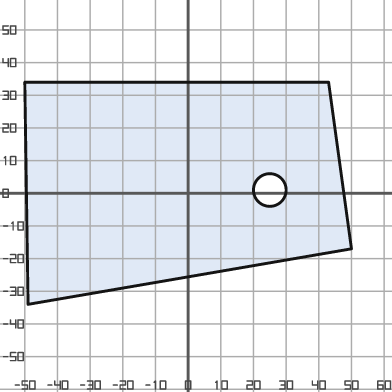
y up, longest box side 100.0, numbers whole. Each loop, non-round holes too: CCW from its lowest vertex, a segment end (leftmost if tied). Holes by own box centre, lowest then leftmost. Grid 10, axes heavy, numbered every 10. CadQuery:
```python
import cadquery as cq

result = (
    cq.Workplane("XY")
    .moveTo(-49.0, -34.0)
    .lineTo(50.0, -17.0)
    .lineTo(43.0, 34.0)
    .lineTo(-50.0, 34.0)
    .close()
    .moveTo(25.0, 1.0)
    .circle(5.0)
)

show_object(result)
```